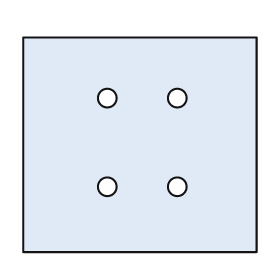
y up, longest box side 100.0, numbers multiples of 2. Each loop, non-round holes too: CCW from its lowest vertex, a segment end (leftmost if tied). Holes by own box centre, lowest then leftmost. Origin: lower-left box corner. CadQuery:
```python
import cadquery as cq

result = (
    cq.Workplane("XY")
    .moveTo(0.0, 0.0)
    .lineTo(100.0, 0.0)
    .lineTo(100.0, 92.0)
    .lineTo(0.0, 92.0)
    .close()
    .moveTo(36.0, 28.0)
    .circle(4.0)
    .moveTo(66.0, 28.0)
    .circle(4.0)
    .moveTo(36.0, 66.0)
    .circle(4.0)
    .moveTo(66.0, 66.0)
    .circle(4.0)
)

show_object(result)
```